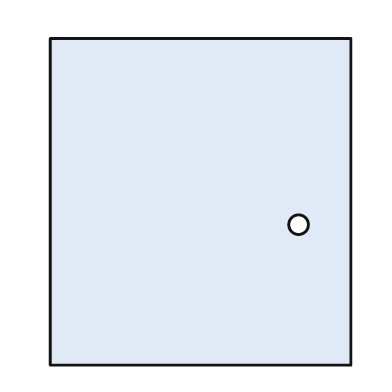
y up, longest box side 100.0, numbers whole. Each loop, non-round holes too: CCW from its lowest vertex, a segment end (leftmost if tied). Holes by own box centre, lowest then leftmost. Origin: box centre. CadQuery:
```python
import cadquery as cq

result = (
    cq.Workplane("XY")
    .moveTo(-46.0, -50.0)
    .lineTo(46.0, -50.0)
    .lineTo(46.0, 50.0)
    .lineTo(-46.0, 50.0)
    .close()
    .moveTo(30.0, -7.0)
    .circle(3.0)
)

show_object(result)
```